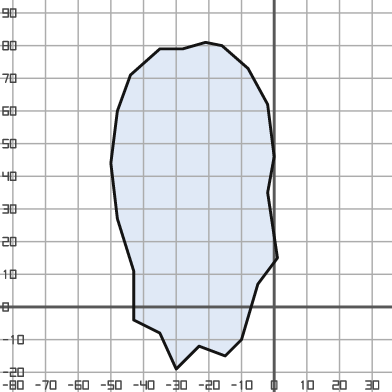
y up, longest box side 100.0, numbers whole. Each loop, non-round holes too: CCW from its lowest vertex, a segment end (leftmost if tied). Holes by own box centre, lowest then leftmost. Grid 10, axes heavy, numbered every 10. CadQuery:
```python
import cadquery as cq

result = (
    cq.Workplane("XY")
    .moveTo(-30.0, -19.0)
    .lineTo(-23.0, -12.0)
    .lineTo(-15.0, -15.0)
    .lineTo(-10.0, -10.0)
    .lineTo(-5.0, 7.0)
    .lineTo(1.0, 15.0)
    .lineTo(-2.0, 35.0)
    .lineTo(0.0, 46.0)
    .lineTo(-2.0, 62.0)
    .lineTo(-8.0, 73.0)
    .lineTo(-16.0, 80.0)
    .lineTo(-21.0, 81.0)
    .lineTo(-28.0, 79.0)
    .lineTo(-35.0, 79.0)
    .lineTo(-44.0, 71.0)
    .lineTo(-48.0, 60.0)
    .lineTo(-50.0, 44.0)
    .lineTo(-48.0, 27.0)
    .lineTo(-43.0, 11.0)
    .lineTo(-43.0, -4.0)
    .lineTo(-35.0, -8.0)
    .close()
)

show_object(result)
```